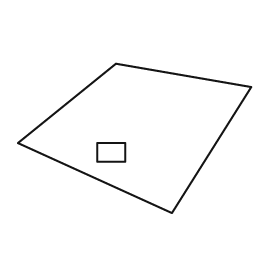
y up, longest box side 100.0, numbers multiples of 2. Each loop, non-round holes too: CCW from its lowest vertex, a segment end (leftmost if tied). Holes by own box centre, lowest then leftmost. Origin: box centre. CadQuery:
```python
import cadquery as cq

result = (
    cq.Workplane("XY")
    .moveTo(16.0, -32.0)
    .lineTo(50.0, 22.0)
    .lineTo(-8.0, 32.0)
    .lineTo(-50.0, -2.0)
    .close()
    .moveTo(-16.0, -10.0)
    .lineTo(-4.0, -10.0)
    .lineTo(-4.0, -2.0)
    .lineTo(-16.0, -2.0)
    .close()
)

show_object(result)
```